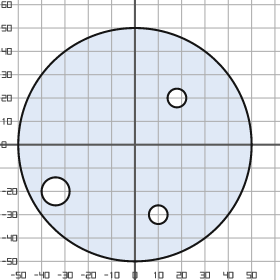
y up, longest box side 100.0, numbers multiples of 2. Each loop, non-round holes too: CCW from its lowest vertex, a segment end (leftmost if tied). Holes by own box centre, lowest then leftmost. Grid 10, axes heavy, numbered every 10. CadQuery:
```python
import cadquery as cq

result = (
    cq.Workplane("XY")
    .moveTo(0.0, 0.0)
    .circle(50.0)
    .moveTo(10.0, -30.0)
    .circle(4.0)
    .moveTo(-34.0, -20.0)
    .circle(6.0)
    .moveTo(18.0, 20.0)
    .circle(4.0)
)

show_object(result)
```